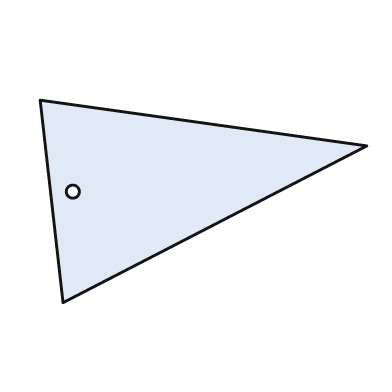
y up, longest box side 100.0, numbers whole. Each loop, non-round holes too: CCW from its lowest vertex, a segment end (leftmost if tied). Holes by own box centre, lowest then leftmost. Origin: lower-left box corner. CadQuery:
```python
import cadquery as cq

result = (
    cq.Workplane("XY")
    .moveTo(7.0, 0.0)
    .lineTo(100.0, 48.0)
    .lineTo(0.0, 62.0)
    .close()
    .moveTo(10.0, 34.0)
    .circle(2.0)
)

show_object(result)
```